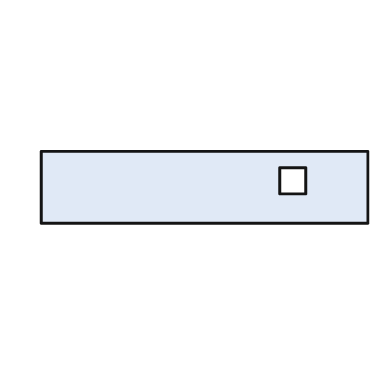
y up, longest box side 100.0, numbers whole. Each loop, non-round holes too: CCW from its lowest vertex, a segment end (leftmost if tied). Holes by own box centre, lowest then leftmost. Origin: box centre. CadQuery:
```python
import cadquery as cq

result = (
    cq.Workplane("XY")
    .moveTo(-50.0, -11.0)
    .lineTo(50.0, -11.0)
    .lineTo(50.0, 11.0)
    .lineTo(-50.0, 11.0)
    .close()
    .moveTo(23.0, -2.0)
    .lineTo(31.0, -2.0)
    .lineTo(31.0, 6.0)
    .lineTo(23.0, 6.0)
    .close()
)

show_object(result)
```